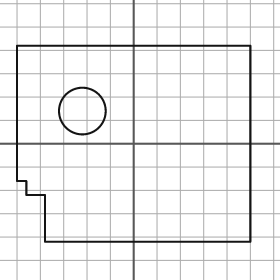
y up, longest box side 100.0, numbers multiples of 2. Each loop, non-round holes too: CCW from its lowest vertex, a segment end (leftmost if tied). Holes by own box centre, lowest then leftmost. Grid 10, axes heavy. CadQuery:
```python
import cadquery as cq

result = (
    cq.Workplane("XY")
    .moveTo(-38.0, -42.0)
    .lineTo(50.0, -42.0)
    .lineTo(50.0, 42.0)
    .lineTo(-50.0, 42.0)
    .lineTo(-50.0, -16.0)
    .lineTo(-46.0, -16.0)
    .lineTo(-46.0, -22.0)
    .lineTo(-38.0, -22.0)
    .close()
    .moveTo(-22.0, 14.0)
    .circle(10.0)
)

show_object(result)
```